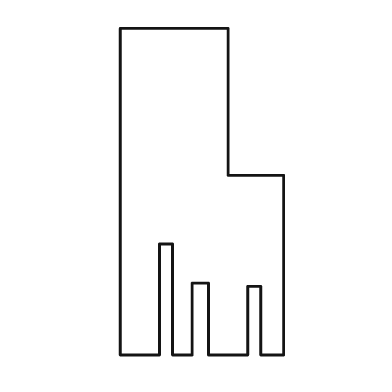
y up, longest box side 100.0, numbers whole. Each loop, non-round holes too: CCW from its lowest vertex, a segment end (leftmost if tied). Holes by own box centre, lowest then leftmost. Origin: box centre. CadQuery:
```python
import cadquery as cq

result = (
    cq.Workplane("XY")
    .moveTo(-25.0, -50.0)
    .lineTo(-13.0, -50.0)
    .lineTo(-13.0, -16.0)
    .lineTo(-9.0, -16.0)
    .lineTo(-9.0, -50.0)
    .lineTo(-3.0, -50.0)
    .lineTo(-3.0, -28.0)
    .lineTo(2.0, -28.0)
    .lineTo(2.0, -50.0)
    .lineTo(14.0, -50.0)
    .lineTo(14.0, -29.0)
    .lineTo(18.0, -29.0)
    .lineTo(18.0, -50.0)
    .lineTo(25.0, -50.0)
    .lineTo(25.0, 5.0)
    .lineTo(8.0, 5.0)
    .lineTo(8.0, 50.0)
    .lineTo(-25.0, 50.0)
    .close()
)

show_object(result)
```